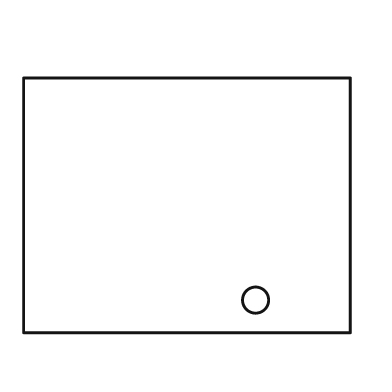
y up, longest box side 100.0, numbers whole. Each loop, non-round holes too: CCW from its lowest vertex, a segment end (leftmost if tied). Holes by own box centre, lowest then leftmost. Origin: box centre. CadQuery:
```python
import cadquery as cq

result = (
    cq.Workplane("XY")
    .moveTo(-50.0, -39.0)
    .lineTo(50.0, -39.0)
    .lineTo(50.0, 39.0)
    .lineTo(-50.0, 39.0)
    .close()
    .moveTo(21.0, -29.0)
    .circle(4.0)
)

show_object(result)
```